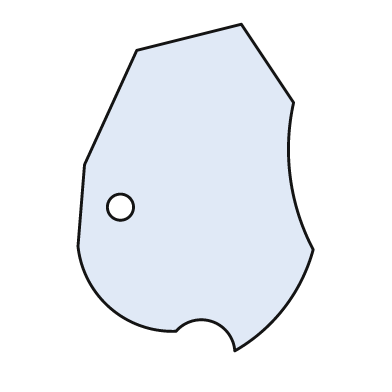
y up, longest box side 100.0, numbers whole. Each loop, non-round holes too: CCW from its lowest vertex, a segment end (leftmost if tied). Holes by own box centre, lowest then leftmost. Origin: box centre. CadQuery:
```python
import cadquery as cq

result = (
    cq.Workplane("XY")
    .moveTo(12.0, -50.0)
    .threePointArc((27.0, -37.0), (36.0, -19.0))
    .threePointArc((29.0, 3.0), (30.0, 26.0))
    .lineTo(14.0, 50.0)
    .lineTo(-18.0, 42.0)
    .lineTo(-34.0, 7.0)
    .lineTo(-36.0, -18.0)
    .threePointArc((-26.0, -37.0), (-6.0, -44.0))
    .threePointArc((5.0, -41.0), (12.0, -50.0))
    .close()
    .moveTo(-23.0, -6.0)
    .circle(4.0)
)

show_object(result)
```